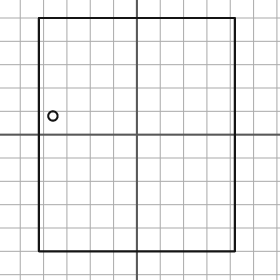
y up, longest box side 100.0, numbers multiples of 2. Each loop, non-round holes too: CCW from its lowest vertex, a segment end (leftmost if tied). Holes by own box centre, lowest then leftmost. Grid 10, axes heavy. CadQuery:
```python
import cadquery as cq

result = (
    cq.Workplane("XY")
    .moveTo(-42.0, -50.0)
    .lineTo(42.0, -50.0)
    .lineTo(42.0, 50.0)
    .lineTo(-42.0, 50.0)
    .close()
    .moveTo(-36.0, 8.0)
    .circle(2.0)
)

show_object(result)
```